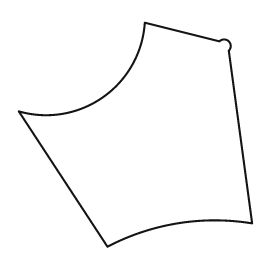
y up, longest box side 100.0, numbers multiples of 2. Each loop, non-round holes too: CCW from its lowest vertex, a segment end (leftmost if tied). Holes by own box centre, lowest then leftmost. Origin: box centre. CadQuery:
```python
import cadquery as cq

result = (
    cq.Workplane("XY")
    .moveTo(-12.0, -48.0)
    .threePointArc((18.0, -38.0), (50.0, -38.0))
    .lineTo(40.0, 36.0)
    .threePointArc((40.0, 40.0), (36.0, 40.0))
    .lineTo(4.0, 48.0)
    .threePointArc((-14.0, 16.0), (-50.0, 10.0))
    .close()
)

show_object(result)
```